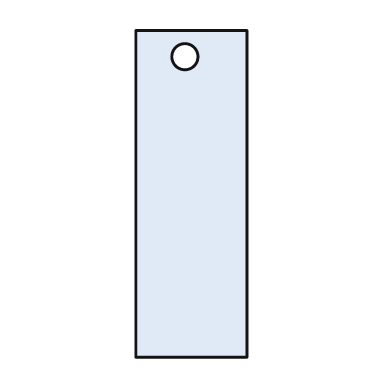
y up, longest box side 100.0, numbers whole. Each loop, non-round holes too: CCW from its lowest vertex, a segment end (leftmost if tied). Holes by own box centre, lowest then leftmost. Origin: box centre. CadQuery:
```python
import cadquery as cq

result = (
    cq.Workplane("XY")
    .moveTo(-17.0, -50.0)
    .lineTo(17.0, -50.0)
    .lineTo(17.0, 50.0)
    .lineTo(-17.0, 50.0)
    .close()
    .moveTo(-2.0, 42.0)
    .circle(4.0)
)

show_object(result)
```